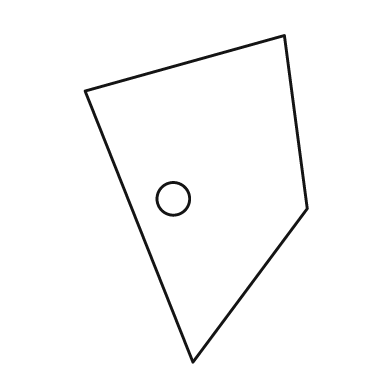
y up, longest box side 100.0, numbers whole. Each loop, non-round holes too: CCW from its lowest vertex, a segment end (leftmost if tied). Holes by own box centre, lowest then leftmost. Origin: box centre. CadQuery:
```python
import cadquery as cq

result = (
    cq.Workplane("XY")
    .moveTo(-1.0, -50.0)
    .lineTo(34.0, -3.0)
    .lineTo(27.0, 50.0)
    .lineTo(-34.0, 33.0)
    .close()
    .moveTo(-7.0, 0.0)
    .circle(5.0)
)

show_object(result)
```